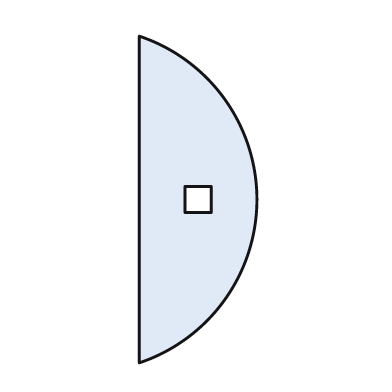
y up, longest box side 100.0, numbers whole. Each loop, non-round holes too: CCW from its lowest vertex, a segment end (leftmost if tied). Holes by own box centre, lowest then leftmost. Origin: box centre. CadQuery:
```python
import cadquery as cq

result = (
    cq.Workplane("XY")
    .moveTo(-18.0, -50.0)
    .threePointArc((18.0, 0.0), (-18.0, 50.0))
    .close()
    .moveTo(-4.0, -4.0)
    .lineTo(4.0, -4.0)
    .lineTo(4.0, 4.0)
    .lineTo(-4.0, 4.0)
    .close()
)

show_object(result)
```